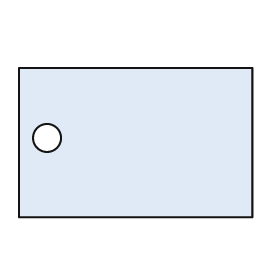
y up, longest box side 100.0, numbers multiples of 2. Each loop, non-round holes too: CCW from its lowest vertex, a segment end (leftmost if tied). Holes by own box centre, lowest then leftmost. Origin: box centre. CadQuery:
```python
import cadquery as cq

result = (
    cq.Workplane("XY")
    .moveTo(-50.0, -32.0)
    .lineTo(50.0, -32.0)
    .lineTo(50.0, 32.0)
    .lineTo(-50.0, 32.0)
    .close()
    .moveTo(-38.0, 2.0)
    .circle(6.0)
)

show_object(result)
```